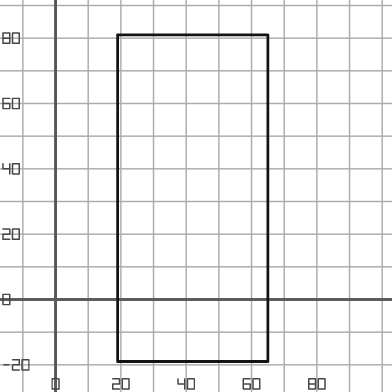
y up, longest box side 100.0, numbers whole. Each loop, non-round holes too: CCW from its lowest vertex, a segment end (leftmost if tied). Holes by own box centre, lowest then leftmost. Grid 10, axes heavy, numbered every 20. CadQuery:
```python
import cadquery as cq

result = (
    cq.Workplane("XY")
    .moveTo(19.0, -19.0)
    .lineTo(65.0, -19.0)
    .lineTo(65.0, 81.0)
    .lineTo(19.0, 81.0)
    .close()
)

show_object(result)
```